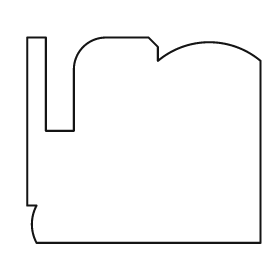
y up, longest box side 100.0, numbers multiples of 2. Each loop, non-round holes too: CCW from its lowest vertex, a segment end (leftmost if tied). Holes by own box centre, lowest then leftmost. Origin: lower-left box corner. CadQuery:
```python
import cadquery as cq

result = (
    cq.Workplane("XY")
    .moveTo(4.0, 0.0)
    .lineTo(100.0, 0.0)
    .lineTo(100.0, 78.0)
    .threePointArc((78.0, 86.0), (56.0, 78.0))
    .lineTo(56.0, 84.0)
    .lineTo(52.0, 88.0)
    .lineTo(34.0, 88.0)
    .threePointArc((24.0, 84.0), (20.0, 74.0))
    .lineTo(20.0, 48.0)
    .lineTo(8.0, 48.0)
    .lineTo(8.0, 88.0)
    .lineTo(0.0, 88.0)
    .lineTo(0.0, 16.0)
    .lineTo(4.0, 16.0)
    .threePointArc((2.0, 8.0), (4.0, 0.0))
    .close()
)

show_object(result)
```